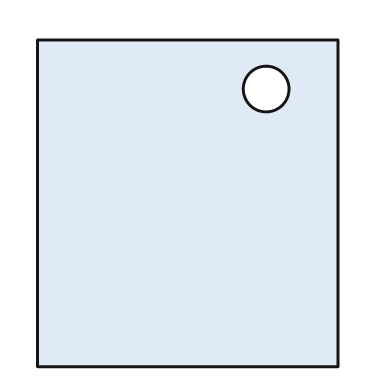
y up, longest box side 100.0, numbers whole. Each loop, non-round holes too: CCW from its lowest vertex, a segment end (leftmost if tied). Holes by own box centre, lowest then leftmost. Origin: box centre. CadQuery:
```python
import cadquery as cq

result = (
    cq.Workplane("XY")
    .moveTo(-46.0, -50.0)
    .lineTo(46.0, -50.0)
    .lineTo(46.0, 50.0)
    .lineTo(-46.0, 50.0)
    .close()
    .moveTo(24.0, 35.0)
    .circle(7.0)
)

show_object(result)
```